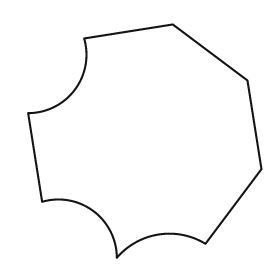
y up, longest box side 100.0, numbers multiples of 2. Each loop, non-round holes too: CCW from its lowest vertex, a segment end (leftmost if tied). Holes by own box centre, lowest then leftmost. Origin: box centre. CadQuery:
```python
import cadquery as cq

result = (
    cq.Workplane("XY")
    .moveTo(-12.0, -50.0)
    .threePointArc((6.0, -40.0), (26.0, -44.0))
    .lineTo(50.0, -12.0)
    .lineTo(44.0, 26.0)
    .lineTo(12.0, 50.0)
    .lineTo(-26.0, 44.0)
    .threePointArc((-30.0, 22.0), (-50.0, 12.0))
    .lineTo(-44.0, -26.0)
    .threePointArc((-22.0, -30.0), (-12.0, -50.0))
    .close()
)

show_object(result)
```